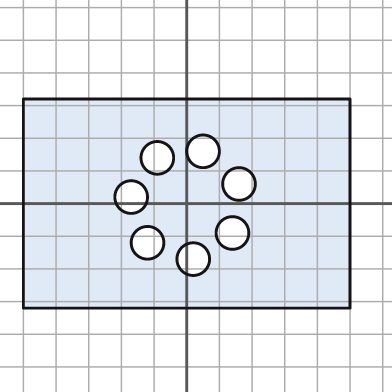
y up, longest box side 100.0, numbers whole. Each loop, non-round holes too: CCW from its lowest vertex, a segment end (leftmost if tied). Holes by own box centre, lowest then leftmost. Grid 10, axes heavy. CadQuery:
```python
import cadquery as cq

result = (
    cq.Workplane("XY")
    .moveTo(-50.0, -32.0)
    .lineTo(50.0, -32.0)
    .lineTo(50.0, 32.0)
    .lineTo(-50.0, 32.0)
    .close()
    .moveTo(2.0, -17.0)
    .circle(5.0)
    .moveTo(-12.0, -12.0)
    .circle(5.0)
    .moveTo(14.0, -9.0)
    .circle(5.0)
    .moveTo(-17.0, 2.0)
    .circle(5.0)
    .moveTo(16.0, 6.0)
    .circle(5.0)
    .moveTo(-9.0, 14.0)
    .circle(5.0)
    .moveTo(5.0, 16.0)
    .circle(5.0)
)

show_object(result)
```